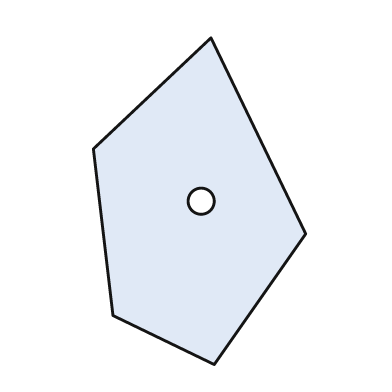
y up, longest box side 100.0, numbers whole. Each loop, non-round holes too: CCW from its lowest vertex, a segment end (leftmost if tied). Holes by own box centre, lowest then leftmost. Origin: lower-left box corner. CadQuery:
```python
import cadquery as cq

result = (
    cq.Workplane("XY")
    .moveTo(37.0, 0.0)
    .lineTo(65.0, 40.0)
    .lineTo(36.0, 100.0)
    .lineTo(0.0, 66.0)
    .lineTo(6.0, 15.0)
    .close()
    .moveTo(33.0, 50.0)
    .circle(4.0)
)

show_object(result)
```